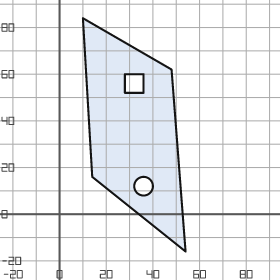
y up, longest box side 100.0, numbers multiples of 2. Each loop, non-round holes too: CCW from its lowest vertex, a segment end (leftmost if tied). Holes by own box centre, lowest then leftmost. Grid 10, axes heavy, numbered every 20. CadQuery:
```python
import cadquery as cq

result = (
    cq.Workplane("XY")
    .moveTo(54.0, -16.0)
    .lineTo(48.0, 62.0)
    .lineTo(10.0, 84.0)
    .lineTo(14.0, 16.0)
    .close()
    .moveTo(36.0, 12.0)
    .circle(4.0)
    .moveTo(28.0, 52.0)
    .lineTo(36.0, 52.0)
    .lineTo(36.0, 60.0)
    .lineTo(28.0, 60.0)
    .close()
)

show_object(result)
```